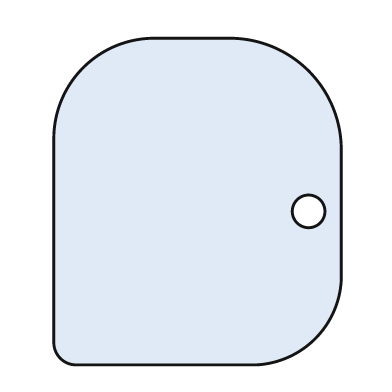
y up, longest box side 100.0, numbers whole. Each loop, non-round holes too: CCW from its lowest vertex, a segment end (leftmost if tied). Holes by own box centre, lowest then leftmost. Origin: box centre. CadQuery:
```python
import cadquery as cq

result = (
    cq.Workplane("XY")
    .moveTo(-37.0, -50.0)
    .lineTo(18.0, -50.0)
    .threePointArc((36.0, -42.0), (44.0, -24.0))
    .lineTo(44.0, 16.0)
    .threePointArc((34.0, 40.0), (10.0, 50.0))
    .lineTo(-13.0, 50.0)
    .threePointArc((-35.0, 41.0), (-44.0, 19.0))
    .lineTo(-44.0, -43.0)
    .threePointArc((-42.0, -48.0), (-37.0, -50.0))
    .close()
    .moveTo(34.0, -3.0)
    .circle(5.0)
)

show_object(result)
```